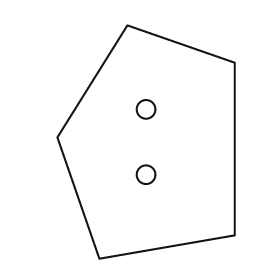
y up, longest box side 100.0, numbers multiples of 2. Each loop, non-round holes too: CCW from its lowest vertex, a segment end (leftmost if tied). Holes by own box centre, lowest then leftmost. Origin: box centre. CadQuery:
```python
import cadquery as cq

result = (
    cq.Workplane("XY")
    .moveTo(-20.0, -50.0)
    .lineTo(38.0, -40.0)
    .lineTo(38.0, 34.0)
    .lineTo(-8.0, 50.0)
    .lineTo(-38.0, 2.0)
    .close()
    .moveTo(0.0, -14.0)
    .circle(4.0)
    .moveTo(0.0, 14.0)
    .circle(4.0)
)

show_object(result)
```